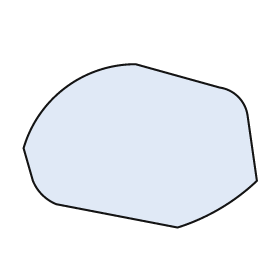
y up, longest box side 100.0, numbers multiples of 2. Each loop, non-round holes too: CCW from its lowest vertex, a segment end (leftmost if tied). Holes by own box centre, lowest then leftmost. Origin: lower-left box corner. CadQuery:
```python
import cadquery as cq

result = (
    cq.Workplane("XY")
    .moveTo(66.0, 0.0)
    .threePointArc((84.0, 8.0), (100.0, 20.0))
    .lineTo(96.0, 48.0)
    .threePointArc((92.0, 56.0), (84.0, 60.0))
    .lineTo(48.0, 70.0)
    .threePointArc((18.0, 60.0), (0.0, 34.0))
    .lineTo(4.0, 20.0)
    .threePointArc((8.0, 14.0), (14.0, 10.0))
    .close()
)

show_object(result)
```